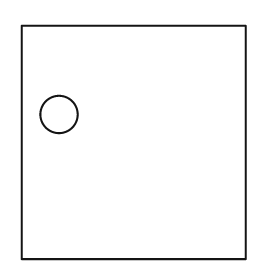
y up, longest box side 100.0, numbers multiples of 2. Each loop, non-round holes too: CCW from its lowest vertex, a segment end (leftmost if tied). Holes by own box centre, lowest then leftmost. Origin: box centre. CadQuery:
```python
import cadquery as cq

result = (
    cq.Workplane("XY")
    .moveTo(-48.0, -50.0)
    .lineTo(48.0, -50.0)
    .lineTo(48.0, 50.0)
    .lineTo(-48.0, 50.0)
    .close()
    .moveTo(-32.0, 12.0)
    .circle(8.0)
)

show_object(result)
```